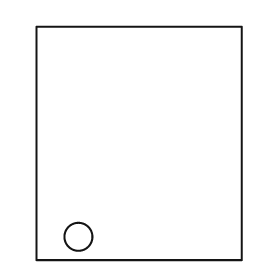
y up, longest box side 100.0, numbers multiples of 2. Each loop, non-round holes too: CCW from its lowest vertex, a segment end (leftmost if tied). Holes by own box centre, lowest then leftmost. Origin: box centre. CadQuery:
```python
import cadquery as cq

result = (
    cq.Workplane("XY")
    .moveTo(-44.0, -50.0)
    .lineTo(44.0, -50.0)
    .lineTo(44.0, 50.0)
    .lineTo(-44.0, 50.0)
    .close()
    .moveTo(-26.0, -40.0)
    .circle(6.0)
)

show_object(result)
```